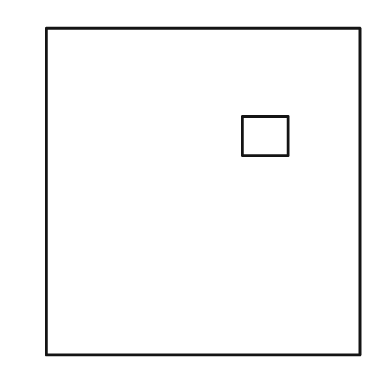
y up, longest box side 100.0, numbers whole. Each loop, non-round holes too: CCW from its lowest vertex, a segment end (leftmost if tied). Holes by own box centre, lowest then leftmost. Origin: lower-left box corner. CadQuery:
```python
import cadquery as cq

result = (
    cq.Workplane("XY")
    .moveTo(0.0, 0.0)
    .lineTo(96.0, 0.0)
    .lineTo(96.0, 100.0)
    .lineTo(0.0, 100.0)
    .close()
    .moveTo(60.0, 61.0)
    .lineTo(74.0, 61.0)
    .lineTo(74.0, 73.0)
    .lineTo(60.0, 73.0)
    .close()
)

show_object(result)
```